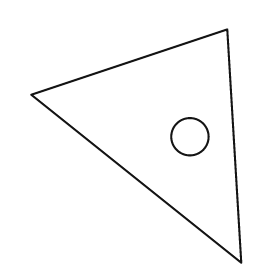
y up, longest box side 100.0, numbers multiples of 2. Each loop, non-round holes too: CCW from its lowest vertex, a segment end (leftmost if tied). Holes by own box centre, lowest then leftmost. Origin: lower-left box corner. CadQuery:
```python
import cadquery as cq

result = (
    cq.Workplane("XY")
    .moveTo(90.0, 0.0)
    .lineTo(84.0, 100.0)
    .lineTo(0.0, 72.0)
    .close()
    .moveTo(68.0, 54.0)
    .circle(8.0)
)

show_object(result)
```